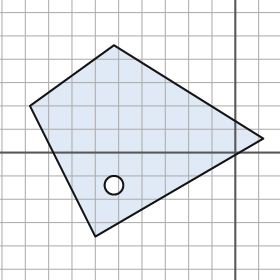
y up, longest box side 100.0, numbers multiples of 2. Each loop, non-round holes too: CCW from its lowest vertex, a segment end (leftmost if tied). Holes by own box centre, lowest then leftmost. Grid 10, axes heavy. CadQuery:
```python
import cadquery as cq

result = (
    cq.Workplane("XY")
    .moveTo(-60.0, -36.0)
    .lineTo(12.0, 6.0)
    .lineTo(-52.0, 46.0)
    .lineTo(-88.0, 20.0)
    .close()
    .moveTo(-52.0, -14.0)
    .circle(4.0)
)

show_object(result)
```